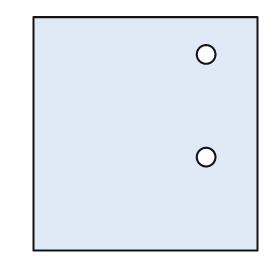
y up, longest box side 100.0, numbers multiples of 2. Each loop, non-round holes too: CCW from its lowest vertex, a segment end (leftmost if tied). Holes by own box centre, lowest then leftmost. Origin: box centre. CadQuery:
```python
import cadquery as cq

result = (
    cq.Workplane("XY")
    .moveTo(-48.0, -50.0)
    .lineTo(48.0, -50.0)
    .lineTo(48.0, 50.0)
    .lineTo(-48.0, 50.0)
    .close()
    .moveTo(26.0, -10.0)
    .circle(4.0)
    .moveTo(26.0, 34.0)
    .circle(4.0)
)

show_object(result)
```